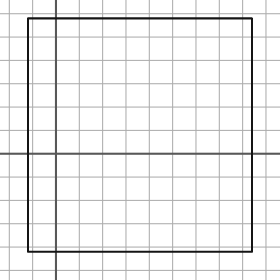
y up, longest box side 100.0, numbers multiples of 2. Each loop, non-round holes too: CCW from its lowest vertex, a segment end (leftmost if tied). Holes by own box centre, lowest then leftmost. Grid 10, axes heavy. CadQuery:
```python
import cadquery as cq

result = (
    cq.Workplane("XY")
    .moveTo(-12.0, -42.0)
    .lineTo(84.0, -42.0)
    .lineTo(84.0, 58.0)
    .lineTo(-12.0, 58.0)
    .close()
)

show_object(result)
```